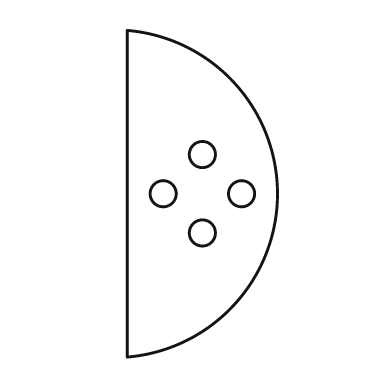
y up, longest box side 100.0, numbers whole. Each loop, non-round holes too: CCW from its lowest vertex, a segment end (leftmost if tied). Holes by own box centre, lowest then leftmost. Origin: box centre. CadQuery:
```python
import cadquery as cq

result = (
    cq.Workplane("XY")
    .moveTo(-23.0, -50.0)
    .threePointArc((23.0, 0.0), (-23.0, 50.0))
    .close()
    .moveTo(0.0, -12.0)
    .circle(4.0)
    .moveTo(-12.0, 0.0)
    .circle(4.0)
    .moveTo(12.0, 0.0)
    .circle(4.0)
    .moveTo(0.0, 12.0)
    .circle(4.0)
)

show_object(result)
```